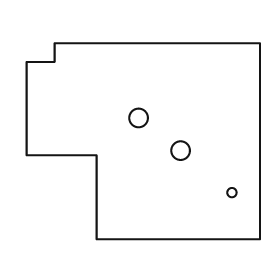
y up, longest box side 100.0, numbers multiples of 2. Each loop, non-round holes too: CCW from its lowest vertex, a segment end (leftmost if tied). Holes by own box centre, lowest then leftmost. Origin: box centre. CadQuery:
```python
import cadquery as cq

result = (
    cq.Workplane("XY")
    .moveTo(-20.0, -42.0)
    .lineTo(50.0, -42.0)
    .lineTo(50.0, 42.0)
    .lineTo(-38.0, 42.0)
    .lineTo(-38.0, 34.0)
    .lineTo(-50.0, 34.0)
    .lineTo(-50.0, -6.0)
    .lineTo(-20.0, -6.0)
    .close()
    .moveTo(38.0, -22.0)
    .circle(2.0)
    .moveTo(16.0, -4.0)
    .circle(4.0)
    .moveTo(-2.0, 10.0)
    .circle(4.0)
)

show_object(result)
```